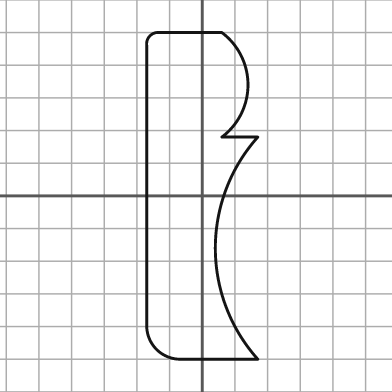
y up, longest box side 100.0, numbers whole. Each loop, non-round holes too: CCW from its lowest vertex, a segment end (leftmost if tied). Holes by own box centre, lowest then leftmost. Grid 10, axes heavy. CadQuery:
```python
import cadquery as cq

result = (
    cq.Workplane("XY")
    .moveTo(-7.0, -50.0)
    .lineTo(17.0, -50.0)
    .threePointArc((4.0, -16.0), (17.0, 18.0))
    .lineTo(6.0, 18.0)
    .threePointArc((14.0, 34.0), (6.0, 50.0))
    .lineTo(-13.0, 50.0)
    .threePointArc((-16.0, 49.0), (-17.0, 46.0))
    .lineTo(-17.0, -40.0)
    .threePointArc((-14.0, -47.0), (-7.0, -50.0))
    .close()
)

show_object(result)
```